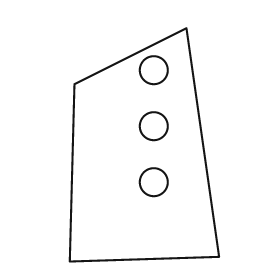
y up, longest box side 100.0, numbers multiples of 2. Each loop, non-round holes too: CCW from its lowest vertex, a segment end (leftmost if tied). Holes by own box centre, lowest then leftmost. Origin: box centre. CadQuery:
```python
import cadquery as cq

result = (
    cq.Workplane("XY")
    .moveTo(-32.0, -50.0)
    .lineTo(32.0, -48.0)
    .lineTo(18.0, 50.0)
    .lineTo(-30.0, 26.0)
    .close()
    .moveTo(4.0, -16.0)
    .circle(6.0)
    .moveTo(4.0, 8.0)
    .circle(6.0)
    .moveTo(4.0, 32.0)
    .circle(6.0)
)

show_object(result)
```